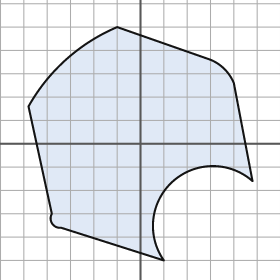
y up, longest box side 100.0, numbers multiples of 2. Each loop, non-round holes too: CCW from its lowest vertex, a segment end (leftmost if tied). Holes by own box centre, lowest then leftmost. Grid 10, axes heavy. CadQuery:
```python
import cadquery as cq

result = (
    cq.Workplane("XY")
    .moveTo(10.0, -50.0)
    .threePointArc((14.0, -16.0), (48.0, -16.0))
    .lineTo(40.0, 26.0)
    .threePointArc((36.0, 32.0), (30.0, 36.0))
    .lineTo(-10.0, 50.0)
    .threePointArc((-32.0, 36.0), (-48.0, 16.0))
    .lineTo(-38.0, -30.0)
    .threePointArc((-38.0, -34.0), (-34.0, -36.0))
    .close()
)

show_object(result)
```